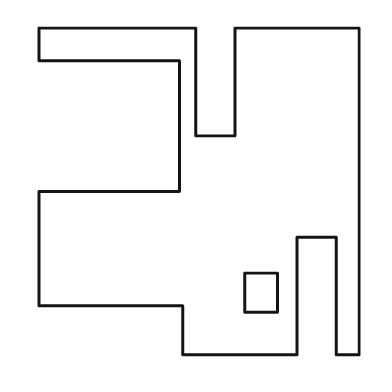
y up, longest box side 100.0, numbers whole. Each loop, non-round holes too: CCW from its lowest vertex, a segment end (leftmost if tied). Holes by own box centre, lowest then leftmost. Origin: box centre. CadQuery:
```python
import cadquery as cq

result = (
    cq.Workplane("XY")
    .moveTo(-5.0, -50.0)
    .lineTo(30.0, -50.0)
    .lineTo(30.0, -14.0)
    .lineTo(42.0, -14.0)
    .lineTo(42.0, -50.0)
    .lineTo(49.0, -50.0)
    .lineTo(49.0, 50.0)
    .lineTo(11.0, 50.0)
    .lineTo(11.0, 17.0)
    .lineTo(-1.0, 17.0)
    .lineTo(-1.0, 50.0)
    .lineTo(-49.0, 50.0)
    .lineTo(-49.0, 40.0)
    .lineTo(-6.0, 40.0)
    .lineTo(-6.0, 0.0)
    .lineTo(-49.0, 0.0)
    .lineTo(-49.0, -35.0)
    .lineTo(-5.0, -35.0)
    .close()
    .moveTo(14.0, -37.0)
    .lineTo(24.0, -37.0)
    .lineTo(24.0, -25.0)
    .lineTo(14.0, -25.0)
    .close()
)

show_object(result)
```